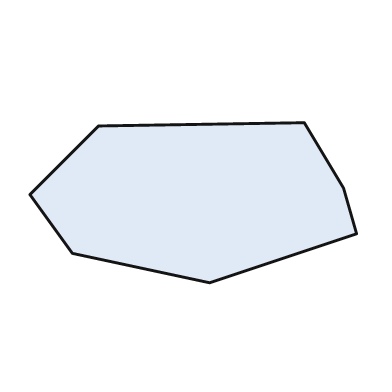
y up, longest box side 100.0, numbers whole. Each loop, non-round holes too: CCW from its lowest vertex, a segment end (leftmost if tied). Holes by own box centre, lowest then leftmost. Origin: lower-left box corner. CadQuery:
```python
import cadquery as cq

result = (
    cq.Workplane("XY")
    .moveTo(55.0, 0.0)
    .lineTo(100.0, 15.0)
    .lineTo(96.0, 29.0)
    .lineTo(84.0, 49.0)
    .lineTo(21.0, 48.0)
    .lineTo(0.0, 27.0)
    .lineTo(13.0, 9.0)
    .close()
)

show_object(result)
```